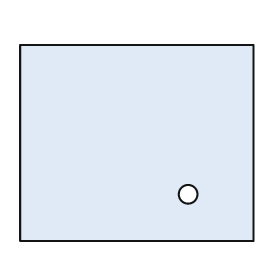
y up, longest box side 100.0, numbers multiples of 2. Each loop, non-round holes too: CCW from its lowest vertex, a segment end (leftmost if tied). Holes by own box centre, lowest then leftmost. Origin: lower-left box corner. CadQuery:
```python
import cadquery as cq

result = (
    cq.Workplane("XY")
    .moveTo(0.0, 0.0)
    .lineTo(100.0, 0.0)
    .lineTo(100.0, 84.0)
    .lineTo(0.0, 84.0)
    .close()
    .moveTo(72.0, 20.0)
    .circle(4.0)
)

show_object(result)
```